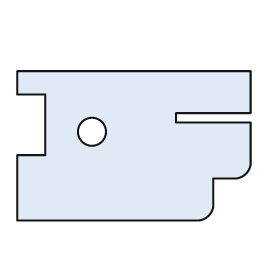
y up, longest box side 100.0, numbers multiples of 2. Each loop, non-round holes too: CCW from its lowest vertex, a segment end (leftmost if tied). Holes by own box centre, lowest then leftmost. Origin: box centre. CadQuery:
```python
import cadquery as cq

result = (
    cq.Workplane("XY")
    .moveTo(-50.0, -32.0)
    .lineTo(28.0, -32.0)
    .threePointArc((32.0, -30.0), (34.0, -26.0))
    .lineTo(34.0, -14.0)
    .lineTo(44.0, -14.0)
    .threePointArc((48.0, -12.0), (50.0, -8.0))
    .lineTo(50.0, 10.0)
    .lineTo(18.0, 10.0)
    .lineTo(18.0, 14.0)
    .lineTo(50.0, 14.0)
    .lineTo(50.0, 32.0)
    .lineTo(-50.0, 32.0)
    .lineTo(-50.0, 22.0)
    .lineTo(-38.0, 22.0)
    .lineTo(-38.0, -4.0)
    .lineTo(-50.0, -4.0)
    .close()
    .moveTo(-18.0, 6.0)
    .circle(6.0)
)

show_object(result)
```